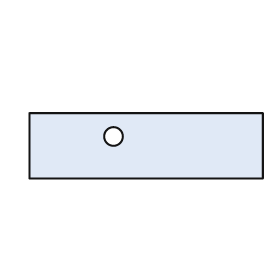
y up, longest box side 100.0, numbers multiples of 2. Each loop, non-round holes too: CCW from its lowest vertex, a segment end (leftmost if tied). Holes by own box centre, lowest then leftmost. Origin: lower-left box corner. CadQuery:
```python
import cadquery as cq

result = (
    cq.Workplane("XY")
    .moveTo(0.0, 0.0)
    .lineTo(100.0, 0.0)
    .lineTo(100.0, 28.0)
    .lineTo(0.0, 28.0)
    .close()
    .moveTo(36.0, 18.0)
    .circle(4.0)
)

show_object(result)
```